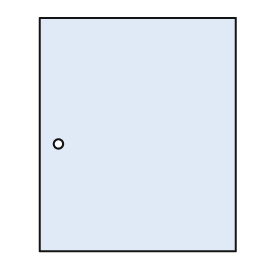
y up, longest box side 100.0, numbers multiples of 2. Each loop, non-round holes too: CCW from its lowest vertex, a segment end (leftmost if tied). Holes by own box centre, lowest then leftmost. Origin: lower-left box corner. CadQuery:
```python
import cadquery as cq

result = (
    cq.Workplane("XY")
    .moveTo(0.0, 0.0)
    .lineTo(84.0, 0.0)
    .lineTo(84.0, 100.0)
    .lineTo(0.0, 100.0)
    .close()
    .moveTo(8.0, 46.0)
    .circle(2.0)
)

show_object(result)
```